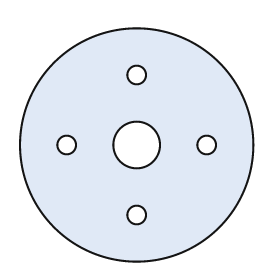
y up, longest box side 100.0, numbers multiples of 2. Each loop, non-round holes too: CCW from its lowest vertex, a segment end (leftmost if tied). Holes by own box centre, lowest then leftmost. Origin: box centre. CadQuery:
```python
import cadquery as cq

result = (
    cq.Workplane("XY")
    .moveTo(0.0, 0.0)
    .circle(50.0)
    .moveTo(0.0, -30.0)
    .circle(4.0)
    .moveTo(-30.0, 0.0)
    .circle(4.0)
    .moveTo(0.0, 0.0)
    .circle(10.0)
    .moveTo(30.0, 0.0)
    .circle(4.0)
    .moveTo(0.0, 30.0)
    .circle(4.0)
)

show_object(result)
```